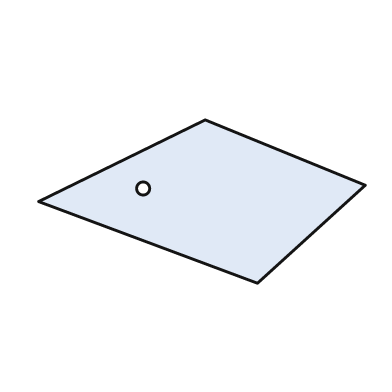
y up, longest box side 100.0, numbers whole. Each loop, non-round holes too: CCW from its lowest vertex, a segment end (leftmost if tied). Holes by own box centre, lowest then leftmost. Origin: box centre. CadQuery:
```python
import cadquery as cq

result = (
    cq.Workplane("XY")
    .moveTo(17.0, -25.0)
    .lineTo(50.0, 5.0)
    .lineTo(1.0, 25.0)
    .lineTo(-50.0, 0.0)
    .close()
    .moveTo(-18.0, 4.0)
    .circle(2.0)
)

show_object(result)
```